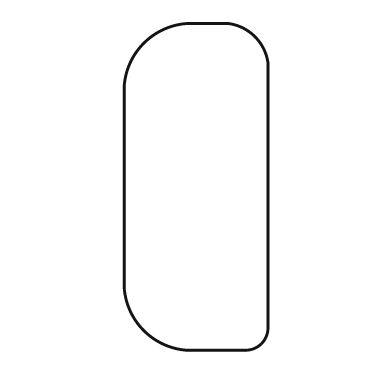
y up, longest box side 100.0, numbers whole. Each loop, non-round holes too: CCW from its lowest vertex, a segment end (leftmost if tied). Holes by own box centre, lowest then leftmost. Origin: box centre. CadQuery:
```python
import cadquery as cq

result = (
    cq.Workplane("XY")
    .moveTo(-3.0, -50.0)
    .lineTo(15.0, -50.0)
    .threePointArc((20.0, -48.0), (22.0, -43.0))
    .lineTo(22.0, 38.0)
    .threePointArc((18.0, 46.0), (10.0, 50.0))
    .lineTo(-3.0, 50.0)
    .threePointArc((-16.0, 44.0), (-22.0, 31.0))
    .lineTo(-22.0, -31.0)
    .threePointArc((-16.0, -44.0), (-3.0, -50.0))
    .close()
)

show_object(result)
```